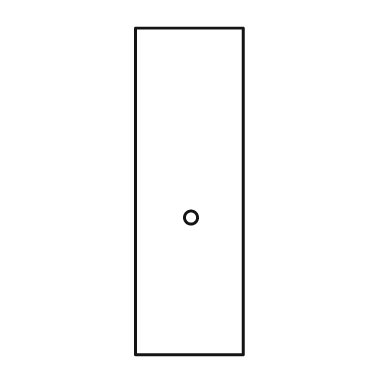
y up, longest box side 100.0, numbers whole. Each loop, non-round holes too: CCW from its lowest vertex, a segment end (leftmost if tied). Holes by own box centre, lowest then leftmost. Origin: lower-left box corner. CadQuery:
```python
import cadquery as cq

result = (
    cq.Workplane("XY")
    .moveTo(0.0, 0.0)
    .lineTo(33.0, 0.0)
    .lineTo(33.0, 100.0)
    .lineTo(0.0, 100.0)
    .close()
    .moveTo(17.0, 42.0)
    .circle(2.0)
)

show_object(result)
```